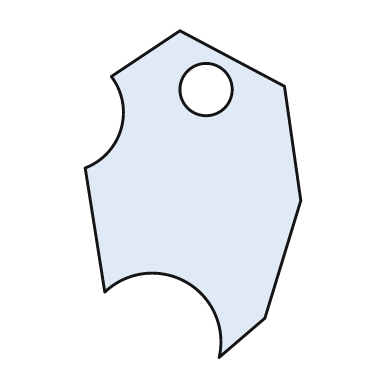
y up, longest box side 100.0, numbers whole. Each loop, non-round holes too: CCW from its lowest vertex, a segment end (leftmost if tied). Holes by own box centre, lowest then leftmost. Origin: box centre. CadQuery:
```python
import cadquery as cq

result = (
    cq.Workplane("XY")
    .moveTo(8.0, -50.0)
    .lineTo(22.0, -38.0)
    .lineTo(33.0, -2.0)
    .lineTo(28.0, 33.0)
    .lineTo(-4.0, 50.0)
    .lineTo(-25.0, 36.0)
    .threePointArc((-22.0, 20.0), (-33.0, 8.0))
    .lineTo(-27.0, -30.0)
    .threePointArc((-2.0, -27.0), (8.0, -50.0))
    .close()
    .moveTo(4.0, 32.0)
    .circle(8.0)
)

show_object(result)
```